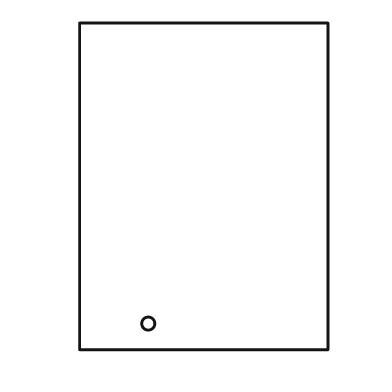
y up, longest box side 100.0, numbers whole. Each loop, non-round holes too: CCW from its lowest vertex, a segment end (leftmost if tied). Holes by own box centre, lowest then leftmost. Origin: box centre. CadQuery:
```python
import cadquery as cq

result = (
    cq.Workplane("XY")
    .moveTo(-38.0, -50.0)
    .lineTo(38.0, -50.0)
    .lineTo(38.0, 50.0)
    .lineTo(-38.0, 50.0)
    .close()
    .moveTo(-17.0, -42.0)
    .circle(2.0)
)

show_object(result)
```